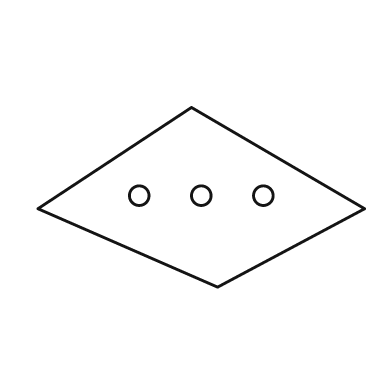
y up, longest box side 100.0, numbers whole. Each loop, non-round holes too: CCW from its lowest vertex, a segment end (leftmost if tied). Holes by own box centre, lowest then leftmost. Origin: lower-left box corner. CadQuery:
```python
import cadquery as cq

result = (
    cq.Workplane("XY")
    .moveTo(55.0, 0.0)
    .lineTo(100.0, 24.0)
    .lineTo(47.0, 55.0)
    .lineTo(0.0, 24.0)
    .close()
    .moveTo(31.0, 28.0)
    .circle(3.0)
    .moveTo(50.0, 28.0)
    .circle(3.0)
    .moveTo(69.0, 28.0)
    .circle(3.0)
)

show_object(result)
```